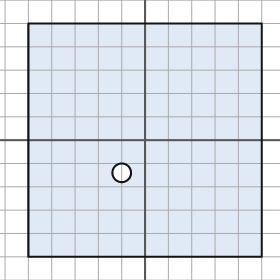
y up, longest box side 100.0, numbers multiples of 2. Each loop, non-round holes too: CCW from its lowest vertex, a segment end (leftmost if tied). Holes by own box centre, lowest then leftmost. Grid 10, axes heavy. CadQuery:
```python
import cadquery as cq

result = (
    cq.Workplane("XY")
    .moveTo(-50.0, -50.0)
    .lineTo(50.0, -50.0)
    .lineTo(50.0, 50.0)
    .lineTo(-50.0, 50.0)
    .close()
    .moveTo(-10.0, -14.0)
    .circle(4.0)
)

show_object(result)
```